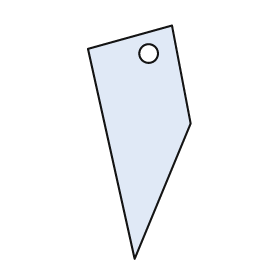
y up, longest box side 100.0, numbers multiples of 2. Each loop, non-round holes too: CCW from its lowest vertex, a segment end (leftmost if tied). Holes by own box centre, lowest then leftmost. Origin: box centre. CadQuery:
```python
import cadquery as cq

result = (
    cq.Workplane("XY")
    .moveTo(-2.0, -50.0)
    .lineTo(22.0, 8.0)
    .lineTo(14.0, 50.0)
    .lineTo(-22.0, 40.0)
    .close()
    .moveTo(4.0, 38.0)
    .circle(4.0)
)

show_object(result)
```